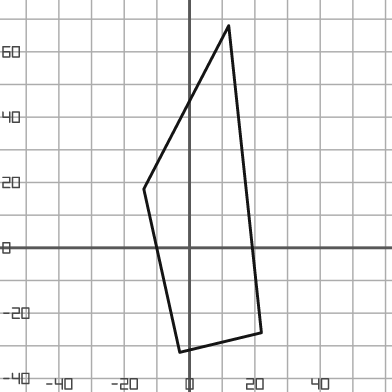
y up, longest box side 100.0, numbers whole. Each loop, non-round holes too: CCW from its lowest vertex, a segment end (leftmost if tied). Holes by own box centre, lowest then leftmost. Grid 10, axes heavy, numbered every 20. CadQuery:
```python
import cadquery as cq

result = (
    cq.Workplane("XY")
    .moveTo(-3.0, -32.0)
    .lineTo(22.0, -26.0)
    .lineTo(12.0, 68.0)
    .lineTo(-14.0, 18.0)
    .close()
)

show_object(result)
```